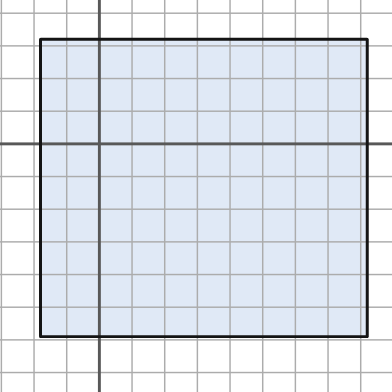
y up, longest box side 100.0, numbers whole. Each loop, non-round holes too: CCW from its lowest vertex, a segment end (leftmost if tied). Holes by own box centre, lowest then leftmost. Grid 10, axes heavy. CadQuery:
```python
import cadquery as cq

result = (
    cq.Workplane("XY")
    .moveTo(-18.0, -59.0)
    .lineTo(82.0, -59.0)
    .lineTo(82.0, 32.0)
    .lineTo(-18.0, 32.0)
    .close()
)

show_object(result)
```